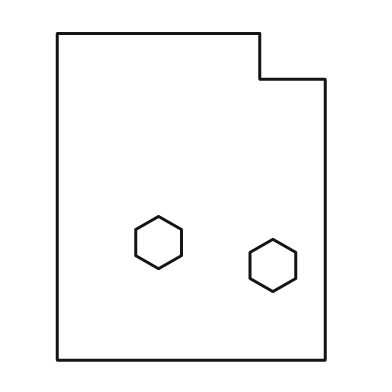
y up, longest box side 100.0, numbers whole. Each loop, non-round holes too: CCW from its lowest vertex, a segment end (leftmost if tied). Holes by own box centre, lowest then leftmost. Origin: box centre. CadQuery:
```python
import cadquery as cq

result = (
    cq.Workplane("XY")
    .moveTo(-41.0, -50.0)
    .lineTo(41.0, -50.0)
    .lineTo(41.0, 36.0)
    .lineTo(21.0, 36.0)
    .lineTo(21.0, 50.0)
    .lineTo(-41.0, 50.0)
    .close()
    .moveTo(25.0, -29.0)
    .lineTo(32.0, -25.0)
    .lineTo(32.0, -17.0)
    .lineTo(25.0, -13.0)
    .lineTo(18.0, -17.0)
    .lineTo(18.0, -25.0)
    .close()
    .moveTo(-10.0, -22.0)
    .lineTo(-3.0, -18.0)
    .lineTo(-3.0, -10.0)
    .lineTo(-10.0, -6.0)
    .lineTo(-17.0, -10.0)
    .lineTo(-17.0, -18.0)
    .close()
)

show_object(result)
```